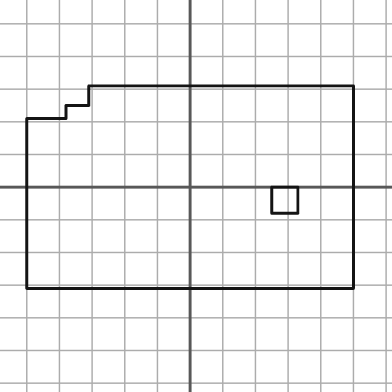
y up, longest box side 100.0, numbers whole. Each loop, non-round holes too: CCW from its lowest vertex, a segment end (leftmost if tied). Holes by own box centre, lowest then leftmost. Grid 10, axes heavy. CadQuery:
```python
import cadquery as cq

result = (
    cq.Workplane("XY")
    .moveTo(-50.0, -31.0)
    .lineTo(50.0, -31.0)
    .lineTo(50.0, 31.0)
    .lineTo(-31.0, 31.0)
    .lineTo(-31.0, 25.0)
    .lineTo(-38.0, 25.0)
    .lineTo(-38.0, 21.0)
    .lineTo(-50.0, 21.0)
    .close()
    .moveTo(25.0, -8.0)
    .lineTo(33.0, -8.0)
    .lineTo(33.0, 0.0)
    .lineTo(25.0, 0.0)
    .close()
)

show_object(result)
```